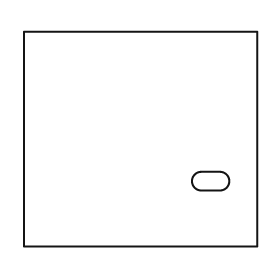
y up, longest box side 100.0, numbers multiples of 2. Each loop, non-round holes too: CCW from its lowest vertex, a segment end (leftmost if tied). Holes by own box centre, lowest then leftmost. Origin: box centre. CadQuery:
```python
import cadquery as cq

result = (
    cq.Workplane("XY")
    .moveTo(-50.0, -46.0)
    .lineTo(50.0, -46.0)
    .lineTo(50.0, 46.0)
    .lineTo(-50.0, 46.0)
    .close()
    .moveTo(26.0, -22.0)
    .lineTo(34.0, -22.0)
    .threePointArc((38.0, -18.0), (34.0, -14.0))
    .lineTo(26.0, -14.0)
    .threePointArc((22.0, -18.0), (26.0, -22.0))
    .close()
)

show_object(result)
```